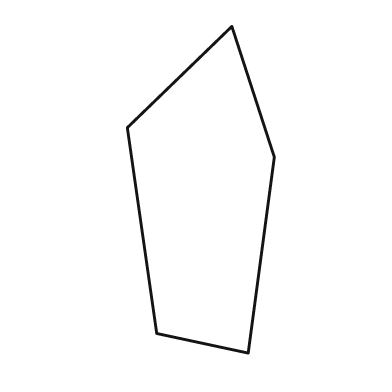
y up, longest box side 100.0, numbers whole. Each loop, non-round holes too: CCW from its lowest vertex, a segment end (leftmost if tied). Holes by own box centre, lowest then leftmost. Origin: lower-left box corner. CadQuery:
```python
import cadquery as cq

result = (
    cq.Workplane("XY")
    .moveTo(37.0, 0.0)
    .lineTo(45.0, 60.0)
    .lineTo(32.0, 100.0)
    .lineTo(0.0, 69.0)
    .lineTo(9.0, 6.0)
    .close()
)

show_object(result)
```